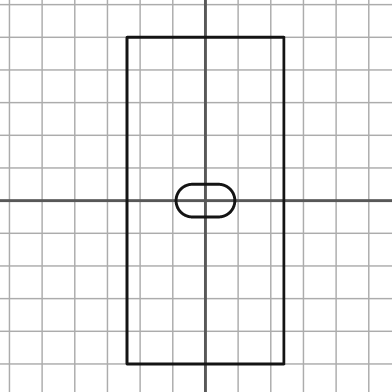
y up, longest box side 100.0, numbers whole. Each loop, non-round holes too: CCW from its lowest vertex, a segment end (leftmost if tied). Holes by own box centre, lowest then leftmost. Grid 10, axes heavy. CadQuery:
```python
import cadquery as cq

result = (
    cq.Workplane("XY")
    .moveTo(-24.0, -50.0)
    .lineTo(24.0, -50.0)
    .lineTo(24.0, 50.0)
    .lineTo(-24.0, 50.0)
    .close()
    .moveTo(-4.0, -5.0)
    .lineTo(4.0, -5.0)
    .threePointArc((9.0, 0.0), (4.0, 5.0))
    .lineTo(-4.0, 5.0)
    .threePointArc((-9.0, 0.0), (-4.0, -5.0))
    .close()
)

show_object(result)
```